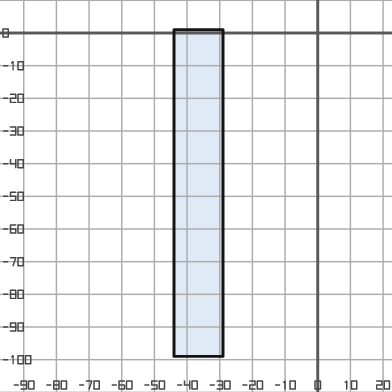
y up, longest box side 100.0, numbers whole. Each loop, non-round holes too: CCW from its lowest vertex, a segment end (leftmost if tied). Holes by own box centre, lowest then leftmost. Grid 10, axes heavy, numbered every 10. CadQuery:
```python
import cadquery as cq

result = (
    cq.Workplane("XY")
    .moveTo(-44.0, -99.0)
    .lineTo(-29.0, -99.0)
    .lineTo(-29.0, 1.0)
    .lineTo(-44.0, 1.0)
    .close()
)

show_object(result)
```